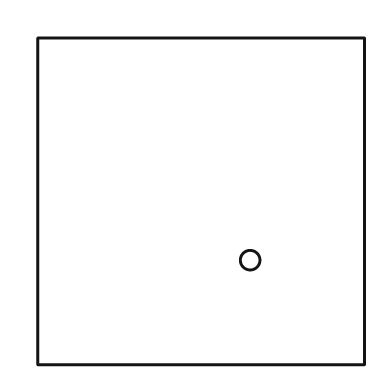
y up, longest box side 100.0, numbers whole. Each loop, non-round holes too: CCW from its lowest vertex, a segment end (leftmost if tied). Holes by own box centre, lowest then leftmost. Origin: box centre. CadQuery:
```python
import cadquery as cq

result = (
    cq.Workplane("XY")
    .moveTo(-50.0, -50.0)
    .lineTo(50.0, -50.0)
    .lineTo(50.0, 50.0)
    .lineTo(-50.0, 50.0)
    .close()
    .moveTo(15.0, -18.0)
    .circle(3.0)
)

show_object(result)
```